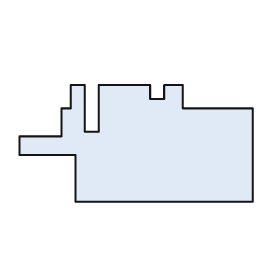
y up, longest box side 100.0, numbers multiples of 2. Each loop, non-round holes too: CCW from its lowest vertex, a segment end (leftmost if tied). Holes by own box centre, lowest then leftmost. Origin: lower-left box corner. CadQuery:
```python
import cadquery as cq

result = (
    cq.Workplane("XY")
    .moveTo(24.0, 0.0)
    .lineTo(100.0, 0.0)
    .lineTo(100.0, 40.0)
    .lineTo(70.0, 40.0)
    .lineTo(70.0, 50.0)
    .lineTo(62.0, 50.0)
    .lineTo(62.0, 44.0)
    .lineTo(56.0, 44.0)
    .lineTo(56.0, 50.0)
    .lineTo(34.0, 50.0)
    .lineTo(34.0, 30.0)
    .lineTo(28.0, 30.0)
    .lineTo(28.0, 50.0)
    .lineTo(22.0, 50.0)
    .lineTo(22.0, 40.0)
    .lineTo(18.0, 40.0)
    .lineTo(18.0, 28.0)
    .lineTo(0.0, 28.0)
    .lineTo(0.0, 20.0)
    .lineTo(24.0, 20.0)
    .close()
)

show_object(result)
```